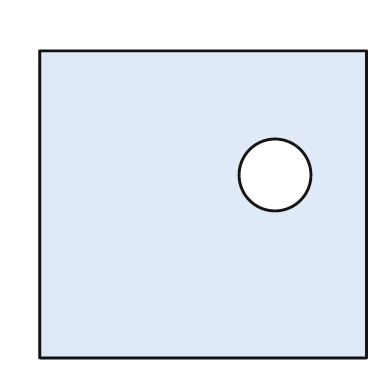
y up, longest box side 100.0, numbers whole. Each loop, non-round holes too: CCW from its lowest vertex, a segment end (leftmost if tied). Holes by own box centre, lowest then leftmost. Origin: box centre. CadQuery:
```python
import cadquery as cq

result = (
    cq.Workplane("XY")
    .moveTo(-50.0, -47.0)
    .lineTo(50.0, -47.0)
    .lineTo(50.0, 47.0)
    .lineTo(-50.0, 47.0)
    .close()
    .moveTo(22.0, 9.0)
    .circle(11.0)
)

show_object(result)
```